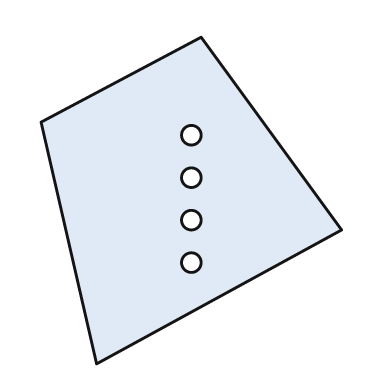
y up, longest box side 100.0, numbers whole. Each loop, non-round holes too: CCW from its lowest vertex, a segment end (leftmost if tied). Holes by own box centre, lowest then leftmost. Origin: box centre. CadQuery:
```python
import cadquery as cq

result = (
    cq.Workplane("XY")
    .moveTo(-29.0, -50.0)
    .lineTo(46.0, -9.0)
    .lineTo(3.0, 50.0)
    .lineTo(-46.0, 24.0)
    .close()
    .moveTo(0.0, -19.0)
    .circle(3.0)
    .moveTo(0.0, -6.0)
    .circle(3.0)
    .moveTo(0.0, 7.0)
    .circle(3.0)
    .moveTo(0.0, 20.0)
    .circle(3.0)
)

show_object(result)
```